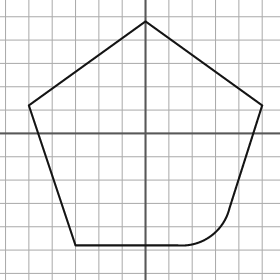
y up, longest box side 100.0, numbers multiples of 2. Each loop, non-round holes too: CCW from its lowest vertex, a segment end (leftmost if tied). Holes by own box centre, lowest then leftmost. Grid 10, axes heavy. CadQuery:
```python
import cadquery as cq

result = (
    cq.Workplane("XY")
    .moveTo(-30.0, -48.0)
    .lineTo(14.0, -48.0)
    .threePointArc((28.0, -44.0), (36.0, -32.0))
    .lineTo(50.0, 12.0)
    .lineTo(0.0, 48.0)
    .lineTo(-50.0, 12.0)
    .close()
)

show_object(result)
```